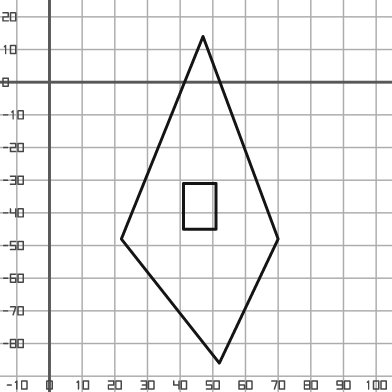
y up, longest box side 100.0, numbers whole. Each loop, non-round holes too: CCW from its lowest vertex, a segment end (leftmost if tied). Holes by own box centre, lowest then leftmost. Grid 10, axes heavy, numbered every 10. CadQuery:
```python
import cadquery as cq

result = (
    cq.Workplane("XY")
    .moveTo(52.0, -86.0)
    .lineTo(70.0, -48.0)
    .lineTo(47.0, 14.0)
    .lineTo(22.0, -48.0)
    .close()
    .moveTo(41.0, -45.0)
    .lineTo(51.0, -45.0)
    .lineTo(51.0, -31.0)
    .lineTo(41.0, -31.0)
    .close()
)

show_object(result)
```